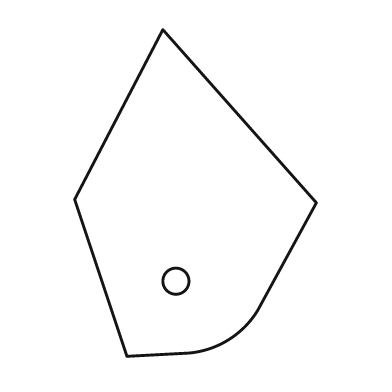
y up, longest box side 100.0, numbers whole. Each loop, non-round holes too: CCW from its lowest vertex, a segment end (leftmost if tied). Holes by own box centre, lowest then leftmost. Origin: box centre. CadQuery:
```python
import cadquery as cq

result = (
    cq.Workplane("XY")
    .moveTo(-21.0, -50.0)
    .lineTo(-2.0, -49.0)
    .threePointArc((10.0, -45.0), (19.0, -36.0))
    .lineTo(37.0, -3.0)
    .lineTo(-10.0, 50.0)
    .lineTo(-37.0, -2.0)
    .close()
    .moveTo(-6.0, -27.0)
    .circle(4.0)
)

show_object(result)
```